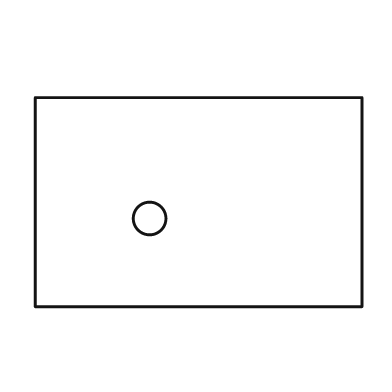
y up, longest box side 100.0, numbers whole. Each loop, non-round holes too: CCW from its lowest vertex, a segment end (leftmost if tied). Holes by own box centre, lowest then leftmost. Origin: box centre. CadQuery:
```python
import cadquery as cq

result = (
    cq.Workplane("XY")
    .moveTo(-50.0, -32.0)
    .lineTo(50.0, -32.0)
    .lineTo(50.0, 32.0)
    .lineTo(-50.0, 32.0)
    .close()
    .moveTo(-15.0, -5.0)
    .circle(5.0)
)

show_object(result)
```